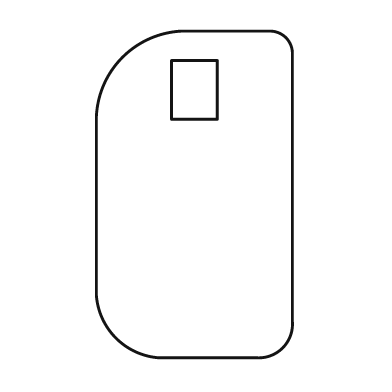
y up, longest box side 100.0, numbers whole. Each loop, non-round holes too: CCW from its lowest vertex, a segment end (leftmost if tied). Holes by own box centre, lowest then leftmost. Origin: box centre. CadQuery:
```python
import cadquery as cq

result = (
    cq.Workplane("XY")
    .moveTo(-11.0, -50.0)
    .lineTo(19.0, -50.0)
    .threePointArc((27.0, -47.0), (30.0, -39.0))
    .lineTo(30.0, 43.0)
    .threePointArc((28.0, 48.0), (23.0, 50.0))
    .lineTo(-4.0, 50.0)
    .threePointArc((-22.0, 42.0), (-30.0, 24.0))
    .lineTo(-30.0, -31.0)
    .threePointArc((-24.0, -44.0), (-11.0, -50.0))
    .close()
    .moveTo(-7.0, 23.0)
    .lineTo(7.0, 23.0)
    .lineTo(7.0, 41.0)
    .lineTo(-7.0, 41.0)
    .close()
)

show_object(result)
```